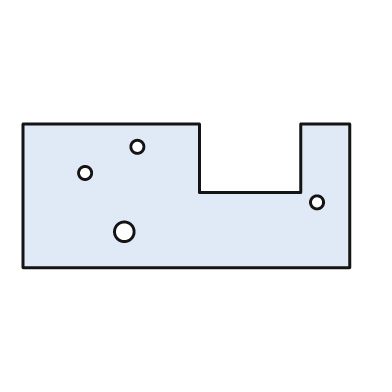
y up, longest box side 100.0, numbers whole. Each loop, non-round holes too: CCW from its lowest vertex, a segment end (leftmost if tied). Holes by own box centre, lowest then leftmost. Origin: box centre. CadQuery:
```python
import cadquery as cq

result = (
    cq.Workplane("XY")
    .moveTo(-50.0, -22.0)
    .lineTo(50.0, -22.0)
    .lineTo(50.0, 22.0)
    .lineTo(35.0, 22.0)
    .lineTo(35.0, 1.0)
    .lineTo(4.0, 1.0)
    .lineTo(4.0, 22.0)
    .lineTo(-50.0, 22.0)
    .close()
    .moveTo(-19.0, -11.0)
    .circle(3.0)
    .moveTo(40.0, -2.0)
    .circle(2.0)
    .moveTo(-31.0, 7.0)
    .circle(2.0)
    .moveTo(-15.0, 15.0)
    .circle(2.0)
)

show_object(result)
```